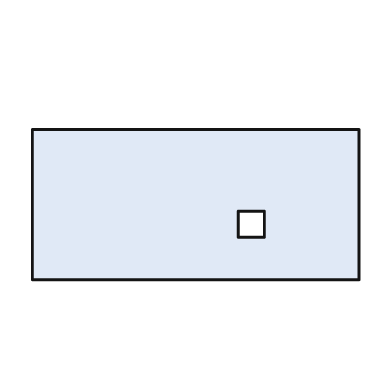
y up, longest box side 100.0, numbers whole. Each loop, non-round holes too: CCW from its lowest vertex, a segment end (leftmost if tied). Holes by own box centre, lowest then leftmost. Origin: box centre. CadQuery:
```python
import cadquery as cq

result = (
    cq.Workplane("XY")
    .moveTo(-50.0, -23.0)
    .lineTo(50.0, -23.0)
    .lineTo(50.0, 23.0)
    .lineTo(-50.0, 23.0)
    .close()
    .moveTo(13.0, -10.0)
    .lineTo(21.0, -10.0)
    .lineTo(21.0, -2.0)
    .lineTo(13.0, -2.0)
    .close()
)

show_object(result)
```